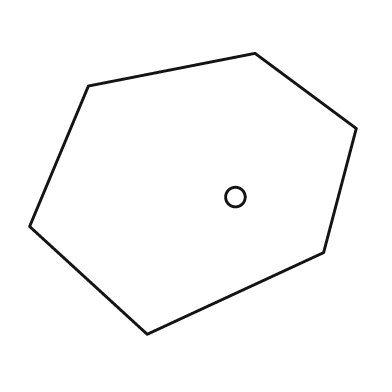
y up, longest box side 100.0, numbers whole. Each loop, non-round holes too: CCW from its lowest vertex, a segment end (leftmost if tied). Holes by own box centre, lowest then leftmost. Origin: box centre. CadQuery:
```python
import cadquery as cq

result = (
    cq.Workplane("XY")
    .moveTo(-14.0, -43.0)
    .lineTo(40.0, -18.0)
    .lineTo(50.0, 20.0)
    .lineTo(19.0, 43.0)
    .lineTo(-32.0, 33.0)
    .lineTo(-50.0, -10.0)
    .close()
    .moveTo(13.0, -1.0)
    .circle(3.0)
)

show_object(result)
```